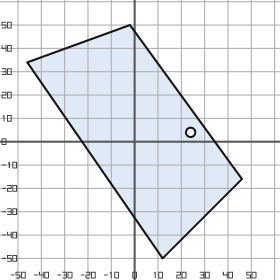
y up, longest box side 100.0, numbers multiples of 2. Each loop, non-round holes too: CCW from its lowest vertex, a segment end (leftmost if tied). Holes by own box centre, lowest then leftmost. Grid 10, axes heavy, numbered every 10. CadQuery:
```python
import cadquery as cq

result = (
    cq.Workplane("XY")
    .moveTo(12.0, -50.0)
    .lineTo(46.0, -16.0)
    .lineTo(-2.0, 50.0)
    .lineTo(-46.0, 34.0)
    .close()
    .moveTo(24.0, 4.0)
    .circle(2.0)
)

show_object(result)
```